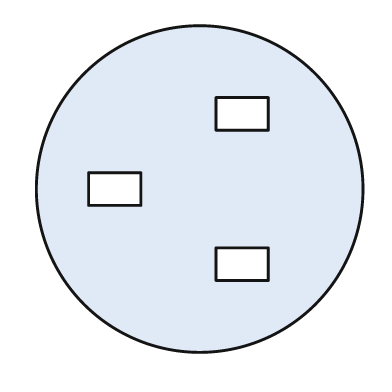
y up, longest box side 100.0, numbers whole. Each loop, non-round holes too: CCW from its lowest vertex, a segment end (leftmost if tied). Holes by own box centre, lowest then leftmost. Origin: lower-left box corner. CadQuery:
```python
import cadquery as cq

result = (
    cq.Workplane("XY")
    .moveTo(50.0, 50.0)
    .circle(50.0)
    .moveTo(55.0, 22.0)
    .lineTo(71.0, 22.0)
    .lineTo(71.0, 32.0)
    .lineTo(55.0, 32.0)
    .close()
    .moveTo(16.0, 45.0)
    .lineTo(32.0, 45.0)
    .lineTo(32.0, 55.0)
    .lineTo(16.0, 55.0)
    .close()
    .moveTo(55.0, 68.0)
    .lineTo(71.0, 68.0)
    .lineTo(71.0, 78.0)
    .lineTo(55.0, 78.0)
    .close()
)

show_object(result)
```